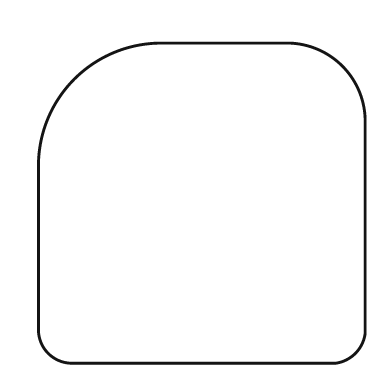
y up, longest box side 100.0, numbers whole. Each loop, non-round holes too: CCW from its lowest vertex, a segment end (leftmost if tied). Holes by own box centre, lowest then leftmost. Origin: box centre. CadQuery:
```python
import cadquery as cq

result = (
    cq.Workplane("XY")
    .moveTo(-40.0, -49.0)
    .lineTo(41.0, -49.0)
    .threePointArc((47.0, -46.0), (50.0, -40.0))
    .lineTo(50.0, 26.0)
    .threePointArc((43.0, 42.0), (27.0, 49.0))
    .lineTo(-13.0, 49.0)
    .threePointArc((-39.0, 38.0), (-50.0, 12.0))
    .lineTo(-50.0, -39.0)
    .threePointArc((-47.0, -46.0), (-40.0, -49.0))
    .close()
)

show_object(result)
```